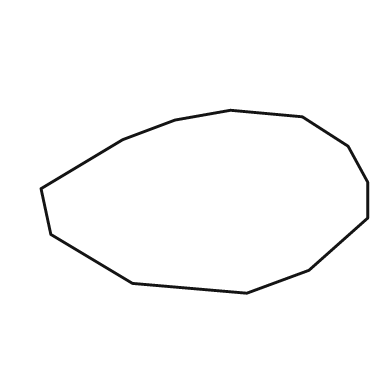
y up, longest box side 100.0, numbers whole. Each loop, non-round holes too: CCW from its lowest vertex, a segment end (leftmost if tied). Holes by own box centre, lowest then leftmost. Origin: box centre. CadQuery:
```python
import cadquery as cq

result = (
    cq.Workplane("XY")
    .moveTo(13.0, -28.0)
    .lineTo(32.0, -21.0)
    .lineTo(50.0, -5.0)
    .lineTo(50.0, 6.0)
    .lineTo(44.0, 17.0)
    .lineTo(30.0, 26.0)
    .lineTo(8.0, 28.0)
    .lineTo(-9.0, 25.0)
    .lineTo(-25.0, 19.0)
    .lineTo(-50.0, 4.0)
    .lineTo(-47.0, -10.0)
    .lineTo(-22.0, -25.0)
    .close()
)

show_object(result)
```